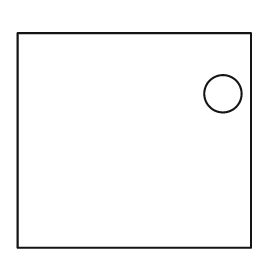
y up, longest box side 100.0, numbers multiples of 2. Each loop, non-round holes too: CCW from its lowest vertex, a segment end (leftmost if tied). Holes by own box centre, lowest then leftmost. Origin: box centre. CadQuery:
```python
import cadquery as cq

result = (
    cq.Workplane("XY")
    .moveTo(-50.0, -46.0)
    .lineTo(50.0, -46.0)
    .lineTo(50.0, 46.0)
    .lineTo(-50.0, 46.0)
    .close()
    .moveTo(38.0, 20.0)
    .circle(8.0)
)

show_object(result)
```